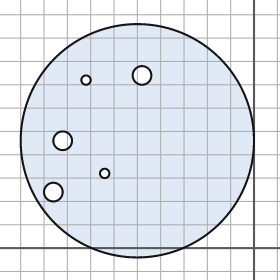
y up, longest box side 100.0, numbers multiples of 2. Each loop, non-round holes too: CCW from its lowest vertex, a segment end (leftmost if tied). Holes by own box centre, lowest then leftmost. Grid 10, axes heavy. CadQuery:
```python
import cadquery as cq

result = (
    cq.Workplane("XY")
    .moveTo(-50.0, 46.0)
    .circle(50.0)
    .moveTo(-86.0, 24.0)
    .circle(4.0)
    .moveTo(-64.0, 32.0)
    .circle(2.0)
    .moveTo(-82.0, 46.0)
    .circle(4.0)
    .moveTo(-72.0, 72.0)
    .circle(2.0)
    .moveTo(-48.0, 74.0)
    .circle(4.0)
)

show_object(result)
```